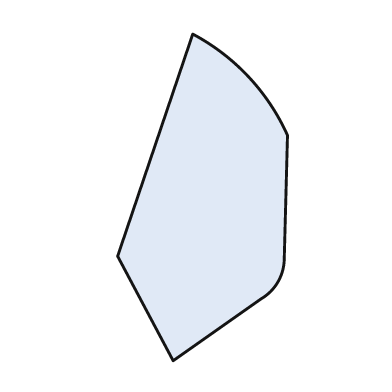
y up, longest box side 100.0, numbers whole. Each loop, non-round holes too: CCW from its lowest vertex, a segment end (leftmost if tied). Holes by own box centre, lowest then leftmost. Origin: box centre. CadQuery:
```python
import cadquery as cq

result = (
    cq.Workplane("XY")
    .moveTo(-9.0, -50.0)
    .lineTo(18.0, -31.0)
    .threePointArc((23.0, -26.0), (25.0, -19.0))
    .lineTo(26.0, 19.0)
    .threePointArc((14.0, 37.0), (-3.0, 50.0))
    .lineTo(-26.0, -18.0)
    .close()
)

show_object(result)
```